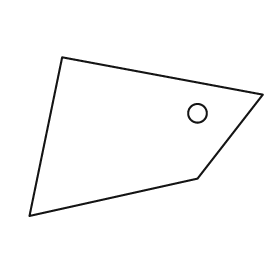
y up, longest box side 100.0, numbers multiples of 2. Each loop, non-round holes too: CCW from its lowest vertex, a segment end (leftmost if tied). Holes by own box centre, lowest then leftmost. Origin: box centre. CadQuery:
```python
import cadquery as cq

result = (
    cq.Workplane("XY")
    .moveTo(-50.0, -34.0)
    .lineTo(22.0, -18.0)
    .lineTo(50.0, 18.0)
    .lineTo(-36.0, 34.0)
    .close()
    .moveTo(22.0, 10.0)
    .circle(4.0)
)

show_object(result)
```